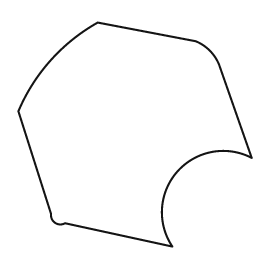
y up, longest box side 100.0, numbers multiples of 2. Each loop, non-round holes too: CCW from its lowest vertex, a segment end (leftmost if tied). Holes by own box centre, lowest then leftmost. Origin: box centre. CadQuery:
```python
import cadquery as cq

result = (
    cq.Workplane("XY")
    .moveTo(16.0, -48.0)
    .threePointArc((18.0, -16.0), (50.0, -10.0))
    .lineTo(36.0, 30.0)
    .threePointArc((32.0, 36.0), (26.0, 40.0))
    .lineTo(-16.0, 48.0)
    .threePointArc((-36.0, 32.0), (-50.0, 10.0))
    .lineTo(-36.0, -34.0)
    .threePointArc((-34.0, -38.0), (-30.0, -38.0))
    .close()
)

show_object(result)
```